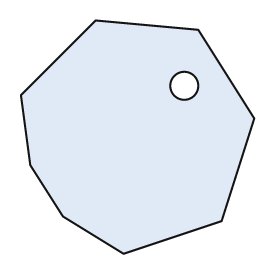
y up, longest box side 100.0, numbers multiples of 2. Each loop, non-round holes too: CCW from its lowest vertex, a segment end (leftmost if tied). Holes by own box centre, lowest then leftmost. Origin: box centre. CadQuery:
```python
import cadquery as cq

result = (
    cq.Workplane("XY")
    .moveTo(-6.0, -50.0)
    .lineTo(36.0, -36.0)
    .lineTo(50.0, 8.0)
    .lineTo(26.0, 46.0)
    .lineTo(-18.0, 50.0)
    .lineTo(-50.0, 18.0)
    .lineTo(-46.0, -12.0)
    .lineTo(-32.0, -34.0)
    .close()
    .moveTo(20.0, 22.0)
    .circle(6.0)
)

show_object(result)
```